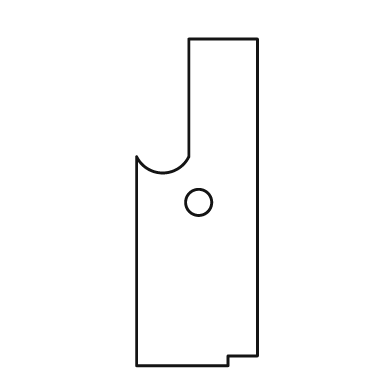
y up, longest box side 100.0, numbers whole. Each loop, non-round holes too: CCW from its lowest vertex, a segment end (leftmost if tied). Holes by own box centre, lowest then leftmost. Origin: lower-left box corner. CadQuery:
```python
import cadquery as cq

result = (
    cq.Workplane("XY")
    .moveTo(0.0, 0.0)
    .lineTo(28.0, 0.0)
    .lineTo(28.0, 3.0)
    .lineTo(37.0, 3.0)
    .lineTo(37.0, 100.0)
    .lineTo(16.0, 100.0)
    .lineTo(16.0, 64.0)
    .threePointArc((8.0, 59.0), (0.0, 64.0))
    .close()
    .moveTo(19.0, 50.0)
    .circle(4.0)
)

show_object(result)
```